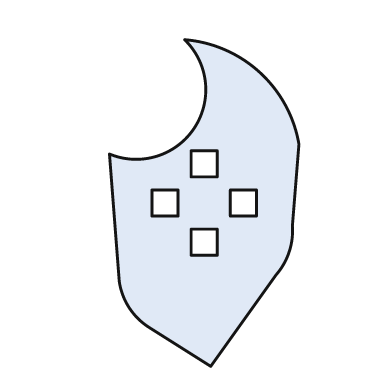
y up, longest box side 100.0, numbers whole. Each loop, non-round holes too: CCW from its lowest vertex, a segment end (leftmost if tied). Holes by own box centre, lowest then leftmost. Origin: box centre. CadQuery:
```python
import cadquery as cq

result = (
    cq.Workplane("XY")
    .moveTo(2.0, -50.0)
    .lineTo(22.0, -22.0)
    .threePointArc((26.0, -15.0), (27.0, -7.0))
    .lineTo(29.0, 18.0)
    .threePointArc((17.0, 40.0), (-6.0, 50.0))
    .threePointArc((-3.0, 23.0), (-29.0, 15.0))
    .lineTo(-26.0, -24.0)
    .threePointArc((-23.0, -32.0), (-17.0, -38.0))
    .close()
    .moveTo(-4.0, -16.0)
    .lineTo(4.0, -16.0)
    .lineTo(4.0, -8.0)
    .lineTo(-4.0, -8.0)
    .close()
    .moveTo(-16.0, -4.0)
    .lineTo(-8.0, -4.0)
    .lineTo(-8.0, 4.0)
    .lineTo(-16.0, 4.0)
    .close()
    .moveTo(8.0, -4.0)
    .lineTo(16.0, -4.0)
    .lineTo(16.0, 4.0)
    .lineTo(8.0, 4.0)
    .close()
    .moveTo(-4.0, 8.0)
    .lineTo(4.0, 8.0)
    .lineTo(4.0, 16.0)
    .lineTo(-4.0, 16.0)
    .close()
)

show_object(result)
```